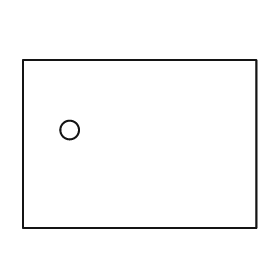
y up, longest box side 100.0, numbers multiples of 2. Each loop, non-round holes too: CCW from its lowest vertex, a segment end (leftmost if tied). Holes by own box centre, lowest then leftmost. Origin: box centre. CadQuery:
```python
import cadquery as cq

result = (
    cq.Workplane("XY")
    .moveTo(-50.0, -36.0)
    .lineTo(50.0, -36.0)
    .lineTo(50.0, 36.0)
    .lineTo(-50.0, 36.0)
    .close()
    .moveTo(-30.0, 6.0)
    .circle(4.0)
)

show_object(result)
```